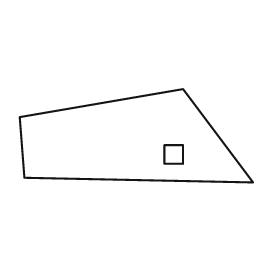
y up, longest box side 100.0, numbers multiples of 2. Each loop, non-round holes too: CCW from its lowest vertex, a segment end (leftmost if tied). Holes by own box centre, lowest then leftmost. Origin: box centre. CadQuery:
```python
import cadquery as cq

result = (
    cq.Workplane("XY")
    .moveTo(50.0, -20.0)
    .lineTo(20.0, 20.0)
    .lineTo(-50.0, 8.0)
    .lineTo(-48.0, -18.0)
    .close()
    .moveTo(12.0, -12.0)
    .lineTo(20.0, -12.0)
    .lineTo(20.0, -4.0)
    .lineTo(12.0, -4.0)
    .close()
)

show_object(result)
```